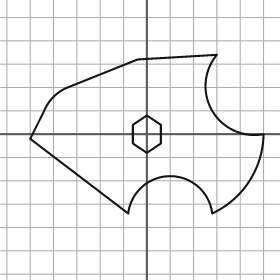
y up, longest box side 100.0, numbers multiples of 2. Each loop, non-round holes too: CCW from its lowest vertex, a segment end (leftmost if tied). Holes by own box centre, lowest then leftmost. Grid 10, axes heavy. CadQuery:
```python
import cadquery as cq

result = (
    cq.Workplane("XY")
    .moveTo(-8.0, -34.0)
    .threePointArc((10.0, -18.0), (28.0, -34.0))
    .threePointArc((44.0, -20.0), (50.0, 0.0))
    .threePointArc((28.0, 10.0), (30.0, 34.0))
    .lineTo(-4.0, 32.0)
    .lineTo(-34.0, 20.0)
    .threePointArc((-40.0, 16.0), (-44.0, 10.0))
    .lineTo(-50.0, -2.0)
    .close()
    .moveTo(0.0, -8.0)
    .lineTo(6.0, -4.0)
    .lineTo(6.0, 4.0)
    .lineTo(0.0, 8.0)
    .lineTo(-6.0, 4.0)
    .lineTo(-6.0, -4.0)
    .close()
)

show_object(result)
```